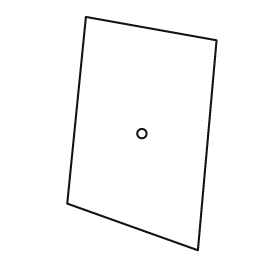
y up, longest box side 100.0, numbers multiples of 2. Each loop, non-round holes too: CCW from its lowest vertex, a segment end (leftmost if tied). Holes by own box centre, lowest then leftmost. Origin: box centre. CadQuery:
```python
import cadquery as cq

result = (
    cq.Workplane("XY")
    .moveTo(24.0, -50.0)
    .lineTo(32.0, 40.0)
    .lineTo(-24.0, 50.0)
    .lineTo(-32.0, -30.0)
    .close()
    .moveTo(0.0, 0.0)
    .circle(2.0)
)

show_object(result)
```